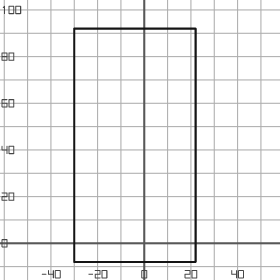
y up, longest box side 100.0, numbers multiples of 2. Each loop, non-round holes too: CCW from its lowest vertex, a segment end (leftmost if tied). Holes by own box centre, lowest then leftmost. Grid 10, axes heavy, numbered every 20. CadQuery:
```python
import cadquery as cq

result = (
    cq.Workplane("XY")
    .moveTo(-30.0, -8.0)
    .lineTo(22.0, -8.0)
    .lineTo(22.0, 92.0)
    .lineTo(-30.0, 92.0)
    .close()
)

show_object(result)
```